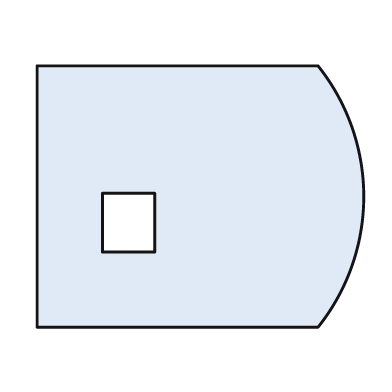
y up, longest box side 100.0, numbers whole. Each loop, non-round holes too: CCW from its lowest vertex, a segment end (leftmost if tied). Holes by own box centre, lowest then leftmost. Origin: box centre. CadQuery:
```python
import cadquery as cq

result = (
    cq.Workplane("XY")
    .moveTo(-50.0, -40.0)
    .lineTo(36.0, -40.0)
    .threePointArc((50.0, 0.0), (36.0, 40.0))
    .lineTo(-50.0, 40.0)
    .close()
    .moveTo(-30.0, -17.0)
    .lineTo(-14.0, -17.0)
    .lineTo(-14.0, 1.0)
    .lineTo(-30.0, 1.0)
    .close()
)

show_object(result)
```